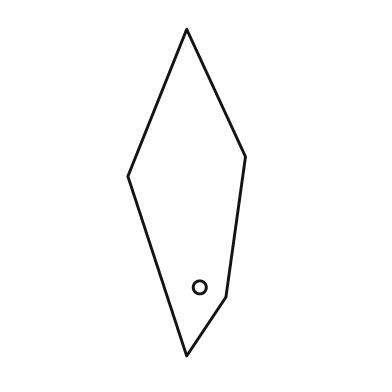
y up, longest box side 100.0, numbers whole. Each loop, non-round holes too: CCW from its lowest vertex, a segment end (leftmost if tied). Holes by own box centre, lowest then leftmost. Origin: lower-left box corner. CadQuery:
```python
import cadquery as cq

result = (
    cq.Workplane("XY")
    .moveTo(18.0, 0.0)
    .lineTo(30.0, 18.0)
    .lineTo(36.0, 61.0)
    .lineTo(18.0, 100.0)
    .lineTo(0.0, 55.0)
    .close()
    .moveTo(22.0, 21.0)
    .circle(2.0)
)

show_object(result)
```